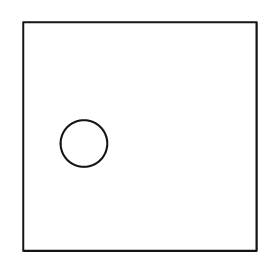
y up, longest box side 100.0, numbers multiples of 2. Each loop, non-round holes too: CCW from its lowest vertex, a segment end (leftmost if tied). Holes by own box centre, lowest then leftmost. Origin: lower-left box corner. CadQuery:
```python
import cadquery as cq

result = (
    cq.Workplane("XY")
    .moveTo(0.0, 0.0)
    .lineTo(100.0, 0.0)
    .lineTo(100.0, 98.0)
    .lineTo(0.0, 98.0)
    .close()
    .moveTo(26.0, 46.0)
    .circle(10.0)
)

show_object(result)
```